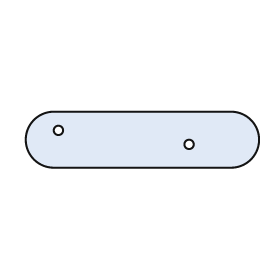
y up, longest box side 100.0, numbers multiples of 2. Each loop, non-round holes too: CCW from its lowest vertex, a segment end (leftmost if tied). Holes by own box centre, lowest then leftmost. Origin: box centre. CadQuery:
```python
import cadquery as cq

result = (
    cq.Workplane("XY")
    .moveTo(-38.0, -12.0)
    .lineTo(38.0, -12.0)
    .threePointArc((50.0, 0.0), (38.0, 12.0))
    .lineTo(-38.0, 12.0)
    .threePointArc((-50.0, 0.0), (-38.0, -12.0))
    .close()
    .moveTo(20.0, -2.0)
    .circle(2.0)
    .moveTo(-36.0, 4.0)
    .circle(2.0)
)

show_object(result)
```